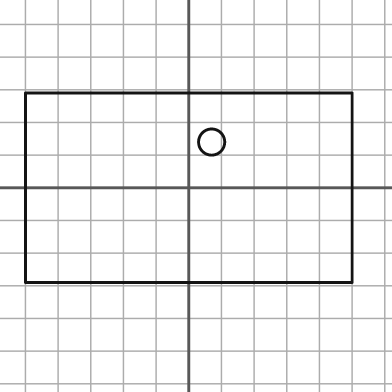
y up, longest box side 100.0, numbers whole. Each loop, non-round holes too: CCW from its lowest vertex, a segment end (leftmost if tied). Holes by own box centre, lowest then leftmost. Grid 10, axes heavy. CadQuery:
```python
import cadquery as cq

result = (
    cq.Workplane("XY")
    .moveTo(-50.0, -29.0)
    .lineTo(50.0, -29.0)
    .lineTo(50.0, 29.0)
    .lineTo(-50.0, 29.0)
    .close()
    .moveTo(7.0, 14.0)
    .circle(4.0)
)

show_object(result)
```